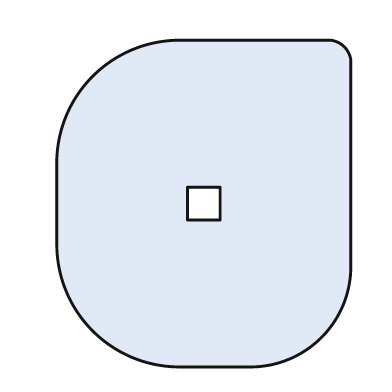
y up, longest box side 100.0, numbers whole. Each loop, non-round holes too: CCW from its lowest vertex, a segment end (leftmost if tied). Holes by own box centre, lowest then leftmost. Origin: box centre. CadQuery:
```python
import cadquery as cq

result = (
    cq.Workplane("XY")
    .moveTo(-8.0, -50.0)
    .lineTo(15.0, -50.0)
    .threePointArc((36.0, -41.0), (45.0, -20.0))
    .lineTo(45.0, 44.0)
    .threePointArc((43.0, 48.0), (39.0, 50.0))
    .lineTo(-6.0, 50.0)
    .threePointArc((-34.0, 39.0), (-45.0, 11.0))
    .lineTo(-45.0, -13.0)
    .threePointArc((-34.0, -39.0), (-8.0, -50.0))
    .close()
    .moveTo(-5.0, -5.0)
    .lineTo(5.0, -5.0)
    .lineTo(5.0, 5.0)
    .lineTo(-5.0, 5.0)
    .close()
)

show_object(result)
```